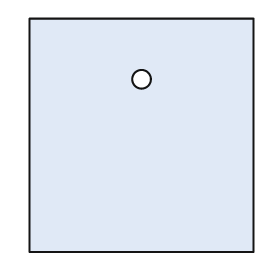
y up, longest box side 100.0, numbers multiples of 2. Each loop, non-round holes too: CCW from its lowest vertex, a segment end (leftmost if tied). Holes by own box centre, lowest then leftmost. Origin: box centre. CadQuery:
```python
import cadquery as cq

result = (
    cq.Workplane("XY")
    .moveTo(-48.0, -50.0)
    .lineTo(48.0, -50.0)
    .lineTo(48.0, 50.0)
    .lineTo(-48.0, 50.0)
    .close()
    .moveTo(0.0, 24.0)
    .circle(4.0)
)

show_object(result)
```